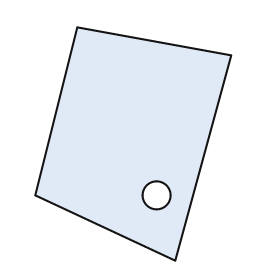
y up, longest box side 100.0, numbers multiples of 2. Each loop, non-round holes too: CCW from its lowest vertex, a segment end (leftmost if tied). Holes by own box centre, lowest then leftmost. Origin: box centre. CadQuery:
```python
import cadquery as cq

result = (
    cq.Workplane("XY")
    .moveTo(18.0, -50.0)
    .lineTo(42.0, 38.0)
    .lineTo(-24.0, 50.0)
    .lineTo(-42.0, -22.0)
    .close()
    .moveTo(10.0, -22.0)
    .circle(6.0)
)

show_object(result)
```